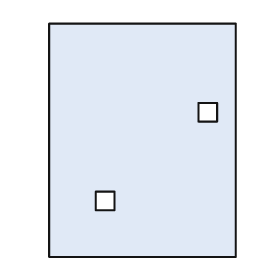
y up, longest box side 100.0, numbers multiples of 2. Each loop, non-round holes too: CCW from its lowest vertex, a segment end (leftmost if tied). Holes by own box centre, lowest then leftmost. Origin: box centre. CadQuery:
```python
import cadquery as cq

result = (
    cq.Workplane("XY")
    .moveTo(-40.0, -50.0)
    .lineTo(40.0, -50.0)
    .lineTo(40.0, 50.0)
    .lineTo(-40.0, 50.0)
    .close()
    .moveTo(-20.0, -30.0)
    .lineTo(-12.0, -30.0)
    .lineTo(-12.0, -22.0)
    .lineTo(-20.0, -22.0)
    .close()
    .moveTo(24.0, 8.0)
    .lineTo(32.0, 8.0)
    .lineTo(32.0, 16.0)
    .lineTo(24.0, 16.0)
    .close()
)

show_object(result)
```